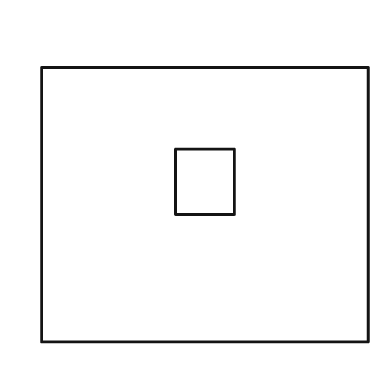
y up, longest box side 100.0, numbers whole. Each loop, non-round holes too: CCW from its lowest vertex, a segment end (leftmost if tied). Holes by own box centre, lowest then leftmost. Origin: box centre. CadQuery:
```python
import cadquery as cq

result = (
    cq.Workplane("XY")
    .moveTo(-50.0, -42.0)
    .lineTo(50.0, -42.0)
    .lineTo(50.0, 42.0)
    .lineTo(-50.0, 42.0)
    .close()
    .moveTo(-9.0, -3.0)
    .lineTo(9.0, -3.0)
    .lineTo(9.0, 17.0)
    .lineTo(-9.0, 17.0)
    .close()
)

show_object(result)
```